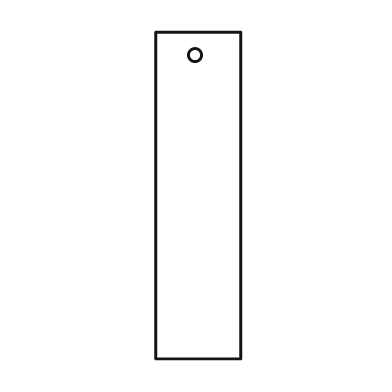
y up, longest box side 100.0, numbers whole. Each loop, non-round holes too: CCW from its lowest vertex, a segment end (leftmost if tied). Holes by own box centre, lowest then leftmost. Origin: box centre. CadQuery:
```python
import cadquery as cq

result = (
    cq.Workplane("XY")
    .moveTo(-13.0, -50.0)
    .lineTo(13.0, -50.0)
    .lineTo(13.0, 50.0)
    .lineTo(-13.0, 50.0)
    .close()
    .moveTo(-1.0, 43.0)
    .circle(2.0)
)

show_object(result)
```